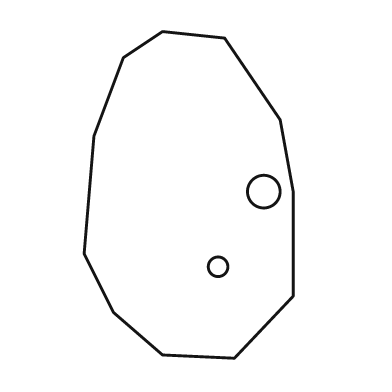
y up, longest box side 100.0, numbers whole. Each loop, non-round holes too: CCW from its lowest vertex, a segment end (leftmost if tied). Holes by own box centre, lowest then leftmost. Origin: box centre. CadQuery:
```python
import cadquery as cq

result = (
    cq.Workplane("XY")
    .moveTo(14.0, -50.0)
    .lineTo(32.0, -31.0)
    .lineTo(32.0, 1.0)
    .lineTo(28.0, 23.0)
    .lineTo(11.0, 48.0)
    .lineTo(-8.0, 50.0)
    .lineTo(-20.0, 42.0)
    .lineTo(-29.0, 18.0)
    .lineTo(-32.0, -18.0)
    .lineTo(-23.0, -36.0)
    .lineTo(-8.0, -49.0)
    .close()
    .moveTo(9.0, -22.0)
    .circle(3.0)
    .moveTo(23.0, 1.0)
    .circle(5.0)
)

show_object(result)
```